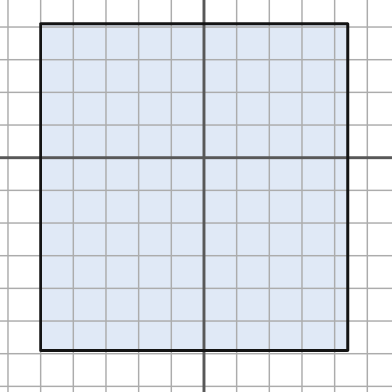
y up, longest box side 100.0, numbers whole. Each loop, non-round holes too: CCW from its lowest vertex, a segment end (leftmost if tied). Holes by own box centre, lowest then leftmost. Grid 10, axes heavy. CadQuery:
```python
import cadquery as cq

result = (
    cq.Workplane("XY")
    .moveTo(-50.0, -59.0)
    .lineTo(44.0, -59.0)
    .lineTo(44.0, 41.0)
    .lineTo(-50.0, 41.0)
    .close()
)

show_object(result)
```